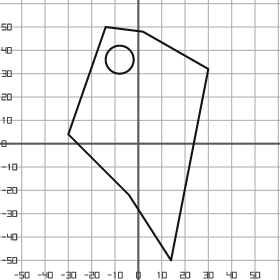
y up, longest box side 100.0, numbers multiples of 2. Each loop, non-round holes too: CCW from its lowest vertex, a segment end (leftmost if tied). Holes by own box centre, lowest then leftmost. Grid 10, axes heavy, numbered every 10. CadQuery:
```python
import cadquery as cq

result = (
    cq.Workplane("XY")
    .moveTo(14.0, -50.0)
    .lineTo(30.0, 32.0)
    .lineTo(2.0, 48.0)
    .lineTo(-14.0, 50.0)
    .lineTo(-30.0, 4.0)
    .lineTo(-4.0, -22.0)
    .close()
    .moveTo(-8.0, 36.0)
    .circle(6.0)
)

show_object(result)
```